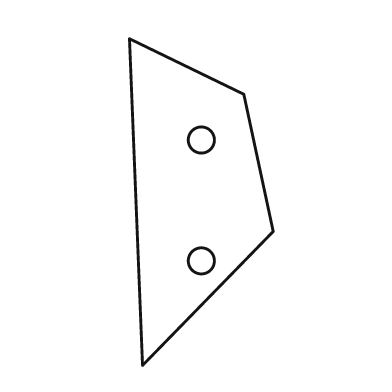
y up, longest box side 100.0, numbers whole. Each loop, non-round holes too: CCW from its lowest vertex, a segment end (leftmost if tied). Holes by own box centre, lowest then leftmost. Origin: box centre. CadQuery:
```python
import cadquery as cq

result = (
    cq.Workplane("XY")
    .moveTo(-18.0, -50.0)
    .lineTo(22.0, -9.0)
    .lineTo(13.0, 33.0)
    .lineTo(-22.0, 50.0)
    .close()
    .moveTo(0.0, -18.0)
    .circle(4.0)
    .moveTo(0.0, 19.0)
    .circle(4.0)
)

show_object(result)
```